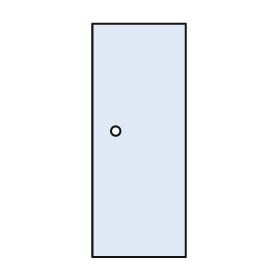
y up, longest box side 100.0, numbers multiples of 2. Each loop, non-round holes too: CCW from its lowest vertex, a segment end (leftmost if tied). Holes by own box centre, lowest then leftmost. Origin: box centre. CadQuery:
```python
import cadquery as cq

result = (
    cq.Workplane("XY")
    .moveTo(-20.0, -50.0)
    .lineTo(20.0, -50.0)
    .lineTo(20.0, 50.0)
    .lineTo(-20.0, 50.0)
    .close()
    .moveTo(-10.0, 4.0)
    .circle(2.0)
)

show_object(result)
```